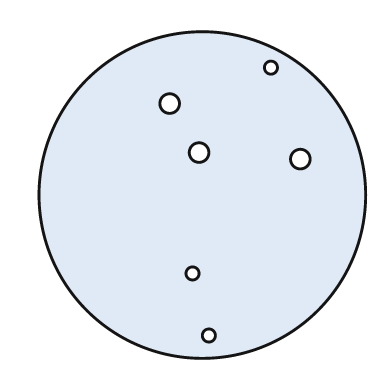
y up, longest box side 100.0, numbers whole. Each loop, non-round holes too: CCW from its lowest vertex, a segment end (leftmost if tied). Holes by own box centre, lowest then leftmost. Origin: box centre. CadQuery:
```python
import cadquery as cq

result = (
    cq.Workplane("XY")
    .moveTo(0.0, 0.0)
    .circle(50.0)
    .moveTo(2.0, -43.0)
    .circle(2.0)
    .moveTo(-3.0, -24.0)
    .circle(2.0)
    .moveTo(30.0, 11.0)
    .circle(3.0)
    .moveTo(-1.0, 13.0)
    .circle(3.0)
    .moveTo(-10.0, 28.0)
    .circle(3.0)
    .moveTo(21.0, 39.0)
    .circle(2.0)
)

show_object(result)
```